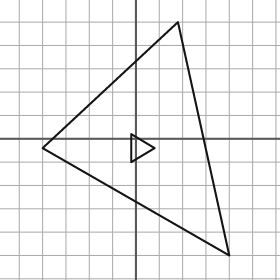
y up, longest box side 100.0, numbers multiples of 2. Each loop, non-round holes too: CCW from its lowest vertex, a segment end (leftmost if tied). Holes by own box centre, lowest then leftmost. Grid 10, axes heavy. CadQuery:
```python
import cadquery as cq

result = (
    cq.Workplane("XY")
    .moveTo(40.0, -50.0)
    .lineTo(18.0, 50.0)
    .lineTo(-40.0, -4.0)
    .close()
    .moveTo(-2.0, -10.0)
    .lineTo(8.0, -4.0)
    .lineTo(-2.0, 2.0)
    .close()
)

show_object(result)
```